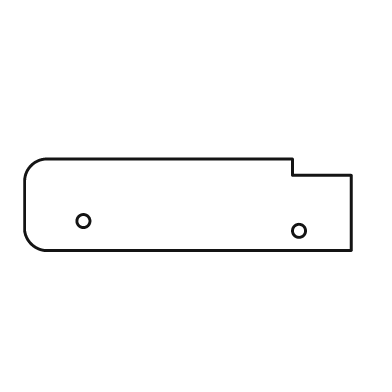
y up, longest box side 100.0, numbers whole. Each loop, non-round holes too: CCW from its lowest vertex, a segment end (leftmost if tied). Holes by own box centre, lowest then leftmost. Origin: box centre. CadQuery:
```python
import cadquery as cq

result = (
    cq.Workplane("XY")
    .moveTo(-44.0, -14.0)
    .lineTo(50.0, -14.0)
    .lineTo(50.0, 9.0)
    .lineTo(32.0, 9.0)
    .lineTo(32.0, 14.0)
    .lineTo(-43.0, 14.0)
    .threePointArc((-48.0, 12.0), (-50.0, 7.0))
    .lineTo(-50.0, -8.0)
    .threePointArc((-48.0, -12.0), (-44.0, -14.0))
    .close()
    .moveTo(34.0, -8.0)
    .circle(2.0)
    .moveTo(-32.0, -5.0)
    .circle(2.0)
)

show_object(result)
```